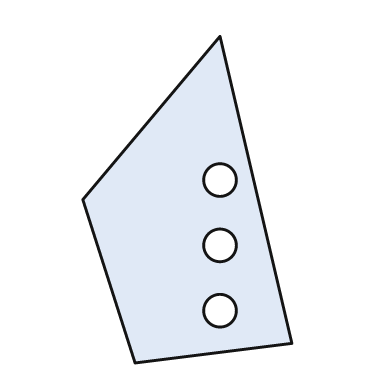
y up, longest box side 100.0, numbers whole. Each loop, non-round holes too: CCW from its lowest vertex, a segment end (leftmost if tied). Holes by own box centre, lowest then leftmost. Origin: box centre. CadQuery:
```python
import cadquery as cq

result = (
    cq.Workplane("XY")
    .moveTo(-16.0, -50.0)
    .lineTo(32.0, -44.0)
    .lineTo(10.0, 50.0)
    .lineTo(-32.0, 0.0)
    .close()
    .moveTo(10.0, -34.0)
    .circle(5.0)
    .moveTo(10.0, -14.0)
    .circle(5.0)
    .moveTo(10.0, 6.0)
    .circle(5.0)
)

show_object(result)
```